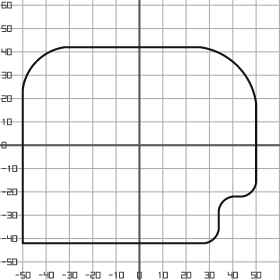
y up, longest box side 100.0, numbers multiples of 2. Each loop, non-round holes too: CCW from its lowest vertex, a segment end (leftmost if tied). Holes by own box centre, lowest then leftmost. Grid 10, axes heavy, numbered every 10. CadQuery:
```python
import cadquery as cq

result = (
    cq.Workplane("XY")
    .moveTo(-50.0, -42.0)
    .lineTo(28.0, -42.0)
    .threePointArc((32.0, -40.0), (34.0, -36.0))
    .lineTo(34.0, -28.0)
    .threePointArc((36.0, -24.0), (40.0, -22.0))
    .lineTo(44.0, -22.0)
    .threePointArc((48.0, -20.0), (50.0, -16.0))
    .lineTo(50.0, 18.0)
    .threePointArc((42.0, 34.0), (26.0, 42.0))
    .lineTo(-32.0, 42.0)
    .threePointArc((-44.0, 36.0), (-50.0, 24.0))
    .close()
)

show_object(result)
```